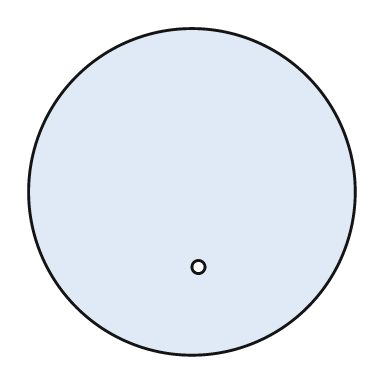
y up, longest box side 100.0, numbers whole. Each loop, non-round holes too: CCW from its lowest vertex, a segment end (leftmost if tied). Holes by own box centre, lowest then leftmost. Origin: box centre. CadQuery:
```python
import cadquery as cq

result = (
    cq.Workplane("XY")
    .moveTo(0.0, 0.0)
    .circle(50.0)
    .moveTo(2.0, -23.0)
    .circle(2.0)
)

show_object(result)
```